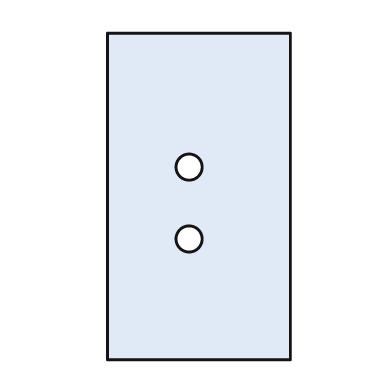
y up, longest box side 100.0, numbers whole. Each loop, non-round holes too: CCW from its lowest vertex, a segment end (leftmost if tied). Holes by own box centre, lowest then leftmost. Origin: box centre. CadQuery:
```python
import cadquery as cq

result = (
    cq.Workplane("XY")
    .moveTo(-28.0, -50.0)
    .lineTo(28.0, -50.0)
    .lineTo(28.0, 50.0)
    .lineTo(-28.0, 50.0)
    .close()
    .moveTo(-3.0, -13.0)
    .circle(4.0)
    .moveTo(-3.0, 9.0)
    .circle(4.0)
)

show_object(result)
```